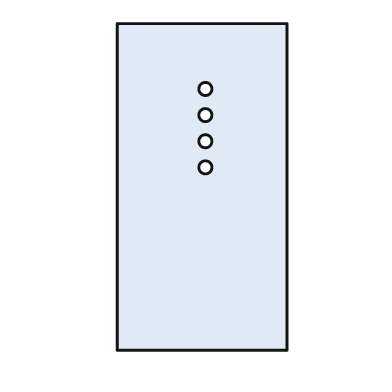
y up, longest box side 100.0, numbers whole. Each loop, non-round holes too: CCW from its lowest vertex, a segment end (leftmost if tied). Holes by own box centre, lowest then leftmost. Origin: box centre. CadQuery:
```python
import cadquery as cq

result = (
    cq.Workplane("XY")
    .moveTo(-26.0, -50.0)
    .lineTo(26.0, -50.0)
    .lineTo(26.0, 50.0)
    .lineTo(-26.0, 50.0)
    .close()
    .moveTo(1.0, 6.0)
    .circle(2.0)
    .moveTo(1.0, 14.0)
    .circle(2.0)
    .moveTo(1.0, 22.0)
    .circle(2.0)
    .moveTo(1.0, 30.0)
    .circle(2.0)
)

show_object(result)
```